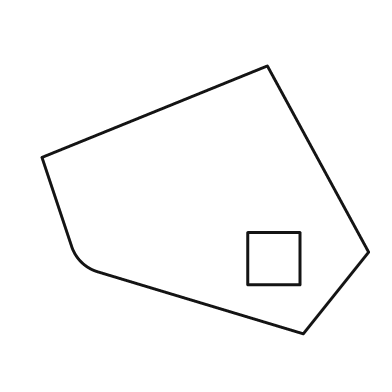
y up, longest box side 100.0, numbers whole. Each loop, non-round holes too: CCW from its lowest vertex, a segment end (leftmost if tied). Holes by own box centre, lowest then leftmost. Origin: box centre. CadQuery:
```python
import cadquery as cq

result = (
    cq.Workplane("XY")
    .moveTo(30.0, -41.0)
    .lineTo(50.0, -16.0)
    .lineTo(19.0, 41.0)
    .lineTo(-50.0, 13.0)
    .lineTo(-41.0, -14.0)
    .threePointArc((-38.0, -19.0), (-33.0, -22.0))
    .close()
    .moveTo(13.0, -26.0)
    .lineTo(29.0, -26.0)
    .lineTo(29.0, -10.0)
    .lineTo(13.0, -10.0)
    .close()
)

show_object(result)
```